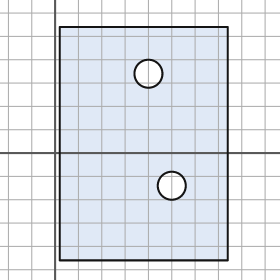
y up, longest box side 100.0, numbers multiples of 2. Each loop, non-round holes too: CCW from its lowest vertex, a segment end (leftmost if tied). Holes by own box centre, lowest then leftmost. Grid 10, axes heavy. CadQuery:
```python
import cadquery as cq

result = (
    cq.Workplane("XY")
    .moveTo(2.0, -46.0)
    .lineTo(74.0, -46.0)
    .lineTo(74.0, 54.0)
    .lineTo(2.0, 54.0)
    .close()
    .moveTo(50.0, -14.0)
    .circle(6.0)
    .moveTo(40.0, 34.0)
    .circle(6.0)
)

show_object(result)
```